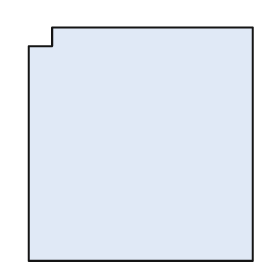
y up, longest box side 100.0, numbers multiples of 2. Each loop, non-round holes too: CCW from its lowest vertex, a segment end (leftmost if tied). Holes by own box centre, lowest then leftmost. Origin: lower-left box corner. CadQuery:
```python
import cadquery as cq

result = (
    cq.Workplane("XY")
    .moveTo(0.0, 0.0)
    .lineTo(96.0, 0.0)
    .lineTo(96.0, 100.0)
    .lineTo(10.0, 100.0)
    .lineTo(10.0, 92.0)
    .lineTo(0.0, 92.0)
    .close()
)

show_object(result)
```